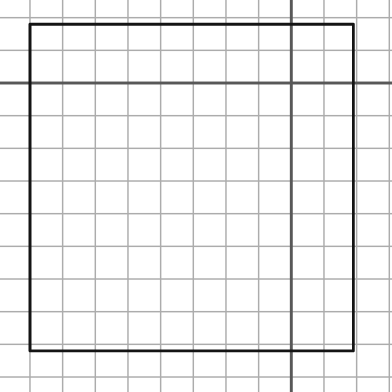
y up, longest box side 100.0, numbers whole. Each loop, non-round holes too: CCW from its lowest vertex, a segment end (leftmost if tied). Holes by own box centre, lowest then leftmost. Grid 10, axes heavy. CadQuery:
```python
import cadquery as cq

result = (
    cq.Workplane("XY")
    .moveTo(-80.0, -82.0)
    .lineTo(19.0, -82.0)
    .lineTo(19.0, 18.0)
    .lineTo(-80.0, 18.0)
    .close()
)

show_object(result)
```